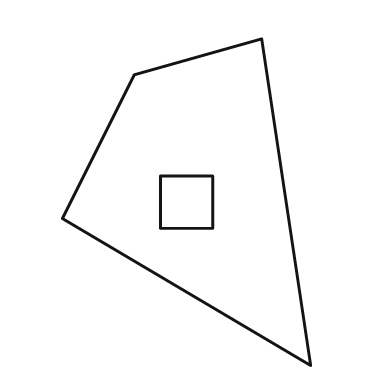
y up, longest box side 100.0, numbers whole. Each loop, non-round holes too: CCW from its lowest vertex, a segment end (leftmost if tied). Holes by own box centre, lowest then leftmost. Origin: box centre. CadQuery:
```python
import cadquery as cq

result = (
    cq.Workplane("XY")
    .moveTo(38.0, -50.0)
    .lineTo(23.0, 50.0)
    .lineTo(-16.0, 39.0)
    .lineTo(-38.0, -5.0)
    .close()
    .moveTo(-8.0, -8.0)
    .lineTo(8.0, -8.0)
    .lineTo(8.0, 8.0)
    .lineTo(-8.0, 8.0)
    .close()
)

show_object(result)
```